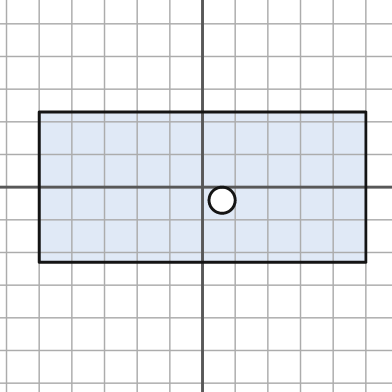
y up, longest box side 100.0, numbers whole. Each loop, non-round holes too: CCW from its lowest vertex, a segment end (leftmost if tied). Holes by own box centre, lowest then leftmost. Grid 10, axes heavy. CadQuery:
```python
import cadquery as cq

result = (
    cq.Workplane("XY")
    .moveTo(-50.0, -23.0)
    .lineTo(50.0, -23.0)
    .lineTo(50.0, 23.0)
    .lineTo(-50.0, 23.0)
    .close()
    .moveTo(6.0, -4.0)
    .circle(4.0)
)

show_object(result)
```